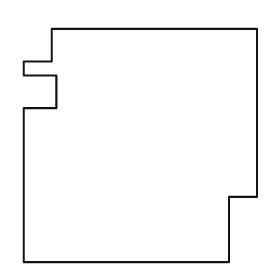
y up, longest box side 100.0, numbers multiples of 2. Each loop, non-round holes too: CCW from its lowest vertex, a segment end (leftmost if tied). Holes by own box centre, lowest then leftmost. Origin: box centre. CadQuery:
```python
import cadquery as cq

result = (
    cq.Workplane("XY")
    .moveTo(-50.0, -50.0)
    .lineTo(38.0, -50.0)
    .lineTo(38.0, -22.0)
    .lineTo(50.0, -22.0)
    .lineTo(50.0, 50.0)
    .lineTo(-38.0, 50.0)
    .lineTo(-38.0, 36.0)
    .lineTo(-50.0, 36.0)
    .lineTo(-50.0, 30.0)
    .lineTo(-36.0, 30.0)
    .lineTo(-36.0, 16.0)
    .lineTo(-50.0, 16.0)
    .close()
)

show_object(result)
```